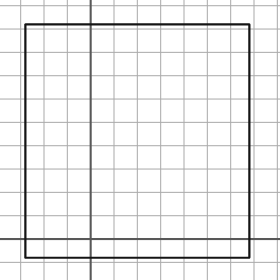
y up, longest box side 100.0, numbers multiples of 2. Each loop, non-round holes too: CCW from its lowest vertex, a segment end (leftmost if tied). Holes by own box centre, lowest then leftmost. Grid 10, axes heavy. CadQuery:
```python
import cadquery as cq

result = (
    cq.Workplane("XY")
    .moveTo(-28.0, -8.0)
    .lineTo(68.0, -8.0)
    .lineTo(68.0, 92.0)
    .lineTo(-28.0, 92.0)
    .close()
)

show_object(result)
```